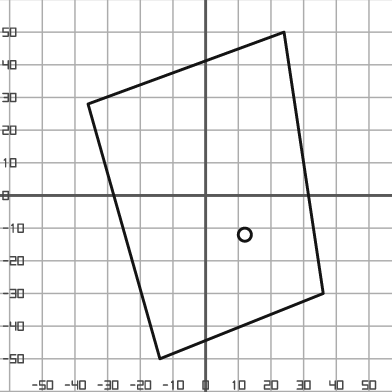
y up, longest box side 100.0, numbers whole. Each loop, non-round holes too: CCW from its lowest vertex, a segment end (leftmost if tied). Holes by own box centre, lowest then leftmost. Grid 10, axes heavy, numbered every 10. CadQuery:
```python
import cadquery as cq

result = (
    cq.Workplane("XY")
    .moveTo(-14.0, -50.0)
    .lineTo(36.0, -30.0)
    .lineTo(24.0, 50.0)
    .lineTo(-36.0, 28.0)
    .close()
    .moveTo(12.0, -12.0)
    .circle(2.0)
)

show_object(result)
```